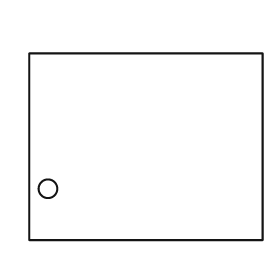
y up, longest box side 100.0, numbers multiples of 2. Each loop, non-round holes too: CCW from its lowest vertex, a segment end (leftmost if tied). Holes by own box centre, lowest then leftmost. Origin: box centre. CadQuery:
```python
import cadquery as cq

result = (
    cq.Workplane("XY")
    .moveTo(-50.0, -40.0)
    .lineTo(50.0, -40.0)
    .lineTo(50.0, 40.0)
    .lineTo(-50.0, 40.0)
    .close()
    .moveTo(-42.0, -18.0)
    .circle(4.0)
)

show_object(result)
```